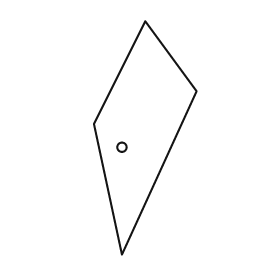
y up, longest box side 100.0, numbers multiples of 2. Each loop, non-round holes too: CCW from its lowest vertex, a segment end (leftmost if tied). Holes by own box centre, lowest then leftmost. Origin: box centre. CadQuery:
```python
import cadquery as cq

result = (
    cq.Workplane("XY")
    .moveTo(-10.0, -50.0)
    .lineTo(22.0, 20.0)
    .lineTo(0.0, 50.0)
    .lineTo(-22.0, 6.0)
    .close()
    .moveTo(-10.0, -4.0)
    .circle(2.0)
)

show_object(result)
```